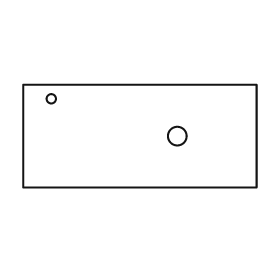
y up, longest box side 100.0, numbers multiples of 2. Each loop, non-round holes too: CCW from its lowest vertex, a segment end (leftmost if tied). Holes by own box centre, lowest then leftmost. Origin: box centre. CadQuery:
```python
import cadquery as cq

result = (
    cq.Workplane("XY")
    .moveTo(-50.0, -22.0)
    .lineTo(50.0, -22.0)
    .lineTo(50.0, 22.0)
    .lineTo(-50.0, 22.0)
    .close()
    .moveTo(16.0, 0.0)
    .circle(4.0)
    .moveTo(-38.0, 16.0)
    .circle(2.0)
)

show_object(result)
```